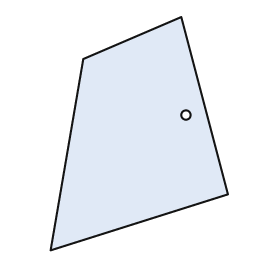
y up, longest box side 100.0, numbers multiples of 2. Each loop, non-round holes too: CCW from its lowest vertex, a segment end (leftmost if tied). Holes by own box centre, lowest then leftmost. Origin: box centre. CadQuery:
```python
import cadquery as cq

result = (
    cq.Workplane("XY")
    .moveTo(-38.0, -50.0)
    .lineTo(38.0, -26.0)
    .lineTo(18.0, 50.0)
    .lineTo(-24.0, 32.0)
    .close()
    .moveTo(20.0, 8.0)
    .circle(2.0)
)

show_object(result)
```